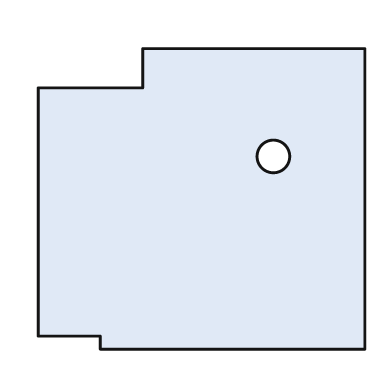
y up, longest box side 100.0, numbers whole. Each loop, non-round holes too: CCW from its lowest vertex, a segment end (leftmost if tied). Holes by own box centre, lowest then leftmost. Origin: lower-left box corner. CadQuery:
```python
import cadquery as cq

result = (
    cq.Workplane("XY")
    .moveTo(19.0, 0.0)
    .lineTo(100.0, 0.0)
    .lineTo(100.0, 92.0)
    .lineTo(32.0, 92.0)
    .lineTo(32.0, 80.0)
    .lineTo(0.0, 80.0)
    .lineTo(0.0, 4.0)
    .lineTo(19.0, 4.0)
    .close()
    .moveTo(72.0, 59.0)
    .circle(5.0)
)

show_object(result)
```